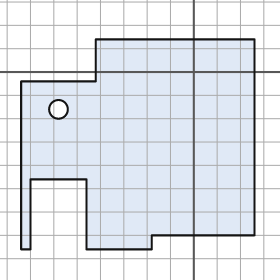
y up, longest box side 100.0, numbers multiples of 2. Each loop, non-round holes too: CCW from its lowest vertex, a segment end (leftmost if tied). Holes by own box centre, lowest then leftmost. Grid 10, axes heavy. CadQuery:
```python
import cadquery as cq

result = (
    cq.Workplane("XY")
    .moveTo(-74.0, -76.0)
    .lineTo(-70.0, -76.0)
    .lineTo(-70.0, -46.0)
    .lineTo(-46.0, -46.0)
    .lineTo(-46.0, -76.0)
    .lineTo(-18.0, -76.0)
    .lineTo(-18.0, -70.0)
    .lineTo(26.0, -70.0)
    .lineTo(26.0, 14.0)
    .lineTo(-42.0, 14.0)
    .lineTo(-42.0, -4.0)
    .lineTo(-74.0, -4.0)
    .close()
    .moveTo(-58.0, -16.0)
    .circle(4.0)
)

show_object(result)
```